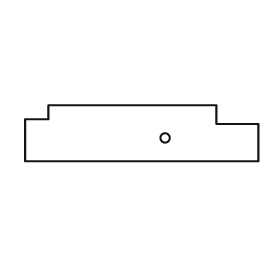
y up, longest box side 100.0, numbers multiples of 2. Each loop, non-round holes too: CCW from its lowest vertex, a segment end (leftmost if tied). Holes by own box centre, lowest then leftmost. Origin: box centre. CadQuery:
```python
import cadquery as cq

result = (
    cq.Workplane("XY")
    .moveTo(-50.0, -12.0)
    .lineTo(50.0, -12.0)
    .lineTo(50.0, 4.0)
    .lineTo(32.0, 4.0)
    .lineTo(32.0, 12.0)
    .lineTo(-40.0, 12.0)
    .lineTo(-40.0, 6.0)
    .lineTo(-50.0, 6.0)
    .close()
    .moveTo(10.0, -2.0)
    .circle(2.0)
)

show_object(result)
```